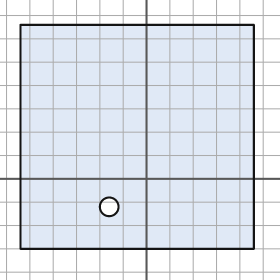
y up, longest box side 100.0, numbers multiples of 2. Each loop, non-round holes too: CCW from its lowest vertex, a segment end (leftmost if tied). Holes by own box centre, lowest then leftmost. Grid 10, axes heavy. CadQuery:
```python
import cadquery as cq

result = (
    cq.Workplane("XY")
    .moveTo(-54.0, -30.0)
    .lineTo(46.0, -30.0)
    .lineTo(46.0, 66.0)
    .lineTo(-54.0, 66.0)
    .close()
    .moveTo(-16.0, -12.0)
    .circle(4.0)
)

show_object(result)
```